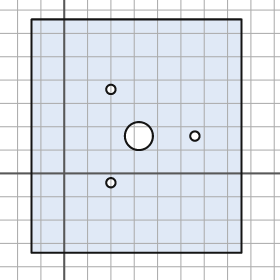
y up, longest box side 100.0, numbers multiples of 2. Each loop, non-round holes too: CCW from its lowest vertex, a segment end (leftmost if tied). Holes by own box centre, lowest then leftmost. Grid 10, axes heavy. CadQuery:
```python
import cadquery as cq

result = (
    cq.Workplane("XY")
    .moveTo(-14.0, -34.0)
    .lineTo(76.0, -34.0)
    .lineTo(76.0, 66.0)
    .lineTo(-14.0, 66.0)
    .close()
    .moveTo(20.0, -4.0)
    .circle(2.0)
    .moveTo(32.0, 16.0)
    .circle(6.0)
    .moveTo(56.0, 16.0)
    .circle(2.0)
    .moveTo(20.0, 36.0)
    .circle(2.0)
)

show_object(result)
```